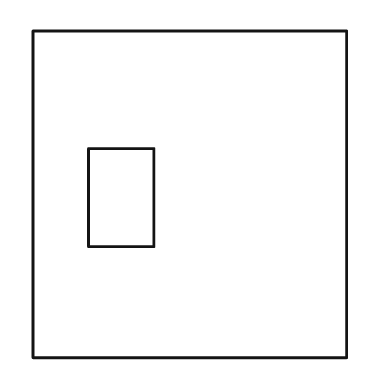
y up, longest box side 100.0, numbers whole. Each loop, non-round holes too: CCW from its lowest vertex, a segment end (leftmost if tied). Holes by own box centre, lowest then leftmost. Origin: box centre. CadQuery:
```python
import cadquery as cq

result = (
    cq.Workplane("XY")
    .moveTo(-48.0, -50.0)
    .lineTo(48.0, -50.0)
    .lineTo(48.0, 50.0)
    .lineTo(-48.0, 50.0)
    .close()
    .moveTo(-31.0, -16.0)
    .lineTo(-11.0, -16.0)
    .lineTo(-11.0, 14.0)
    .lineTo(-31.0, 14.0)
    .close()
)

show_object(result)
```